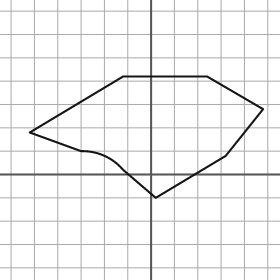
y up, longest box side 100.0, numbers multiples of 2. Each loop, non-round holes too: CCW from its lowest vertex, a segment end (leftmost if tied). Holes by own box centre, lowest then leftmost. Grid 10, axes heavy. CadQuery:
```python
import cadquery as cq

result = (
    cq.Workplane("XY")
    .moveTo(2.0, -10.0)
    .lineTo(32.0, 8.0)
    .lineTo(48.0, 28.0)
    .lineTo(24.0, 42.0)
    .lineTo(-12.0, 42.0)
    .lineTo(-52.0, 18.0)
    .lineTo(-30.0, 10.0)
    .threePointArc((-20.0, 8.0), (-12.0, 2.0))
    .close()
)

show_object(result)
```